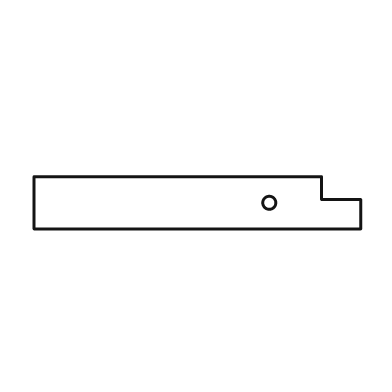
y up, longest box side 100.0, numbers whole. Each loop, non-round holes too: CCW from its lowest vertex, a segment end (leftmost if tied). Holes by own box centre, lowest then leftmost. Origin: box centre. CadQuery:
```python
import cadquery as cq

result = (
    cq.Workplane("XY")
    .moveTo(-50.0, -8.0)
    .lineTo(50.0, -8.0)
    .lineTo(50.0, 1.0)
    .lineTo(38.0, 1.0)
    .lineTo(38.0, 8.0)
    .lineTo(-50.0, 8.0)
    .close()
    .moveTo(22.0, 0.0)
    .circle(2.0)
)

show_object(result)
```